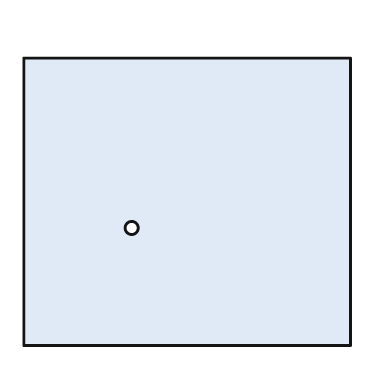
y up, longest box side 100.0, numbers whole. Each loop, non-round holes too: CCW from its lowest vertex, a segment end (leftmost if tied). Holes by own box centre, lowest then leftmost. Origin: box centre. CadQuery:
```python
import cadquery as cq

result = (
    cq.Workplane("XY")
    .moveTo(-50.0, -44.0)
    .lineTo(50.0, -44.0)
    .lineTo(50.0, 44.0)
    .lineTo(-50.0, 44.0)
    .close()
    .moveTo(-17.0, -8.0)
    .circle(2.0)
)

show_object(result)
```